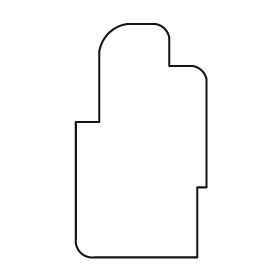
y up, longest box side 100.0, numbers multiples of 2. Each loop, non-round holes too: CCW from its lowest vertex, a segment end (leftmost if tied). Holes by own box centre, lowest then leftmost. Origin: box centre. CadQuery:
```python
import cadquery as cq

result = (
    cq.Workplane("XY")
    .moveTo(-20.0, -50.0)
    .lineTo(24.0, -50.0)
    .lineTo(24.0, -20.0)
    .lineTo(28.0, -20.0)
    .lineTo(28.0, 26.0)
    .threePointArc((26.0, 30.0), (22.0, 32.0))
    .lineTo(12.0, 32.0)
    .lineTo(12.0, 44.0)
    .threePointArc((10.0, 48.0), (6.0, 50.0))
    .lineTo(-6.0, 50.0)
    .threePointArc((-14.0, 46.0), (-18.0, 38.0))
    .lineTo(-18.0, 8.0)
    .lineTo(-28.0, 8.0)
    .lineTo(-28.0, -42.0)
    .threePointArc((-26.0, -48.0), (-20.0, -50.0))
    .close()
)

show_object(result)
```